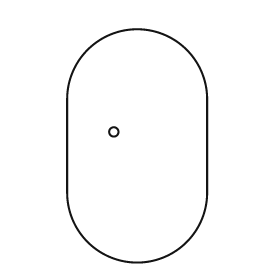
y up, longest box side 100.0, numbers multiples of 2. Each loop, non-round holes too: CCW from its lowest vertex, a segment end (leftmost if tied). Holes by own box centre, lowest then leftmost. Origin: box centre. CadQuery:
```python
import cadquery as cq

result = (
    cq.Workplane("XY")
    .moveTo(-30.0, -20.0)
    .threePointArc((0.0, -50.0), (30.0, -20.0))
    .lineTo(30.0, 20.0)
    .threePointArc((0.0, 50.0), (-30.0, 20.0))
    .close()
    .moveTo(-10.0, 6.0)
    .circle(2.0)
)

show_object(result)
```